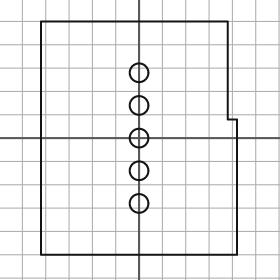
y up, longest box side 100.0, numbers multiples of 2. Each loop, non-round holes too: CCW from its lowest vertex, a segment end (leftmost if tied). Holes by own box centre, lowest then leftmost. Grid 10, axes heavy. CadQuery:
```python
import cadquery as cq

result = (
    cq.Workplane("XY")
    .moveTo(-42.0, -50.0)
    .lineTo(42.0, -50.0)
    .lineTo(42.0, 8.0)
    .lineTo(38.0, 8.0)
    .lineTo(38.0, 50.0)
    .lineTo(-42.0, 50.0)
    .close()
    .moveTo(0.0, -28.0)
    .circle(4.0)
    .moveTo(0.0, -14.0)
    .circle(4.0)
    .moveTo(0.0, 0.0)
    .circle(4.0)
    .moveTo(0.0, 14.0)
    .circle(4.0)
    .moveTo(0.0, 28.0)
    .circle(4.0)
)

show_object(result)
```